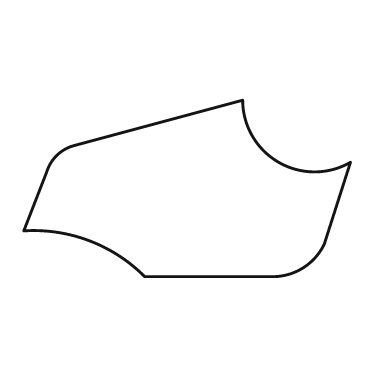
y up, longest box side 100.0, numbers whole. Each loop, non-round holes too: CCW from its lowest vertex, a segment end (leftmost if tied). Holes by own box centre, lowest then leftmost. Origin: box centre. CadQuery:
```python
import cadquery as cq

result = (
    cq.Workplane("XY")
    .moveTo(-13.0, -27.0)
    .lineTo(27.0, -27.0)
    .threePointArc((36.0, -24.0), (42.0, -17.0))
    .lineTo(50.0, 8.0)
    .threePointArc((28.0, 8.0), (17.0, 27.0))
    .lineTo(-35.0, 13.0)
    .threePointArc((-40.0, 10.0), (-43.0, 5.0))
    .lineTo(-50.0, -13.0)
    .threePointArc((-30.0, -16.0), (-13.0, -27.0))
    .close()
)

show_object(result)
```